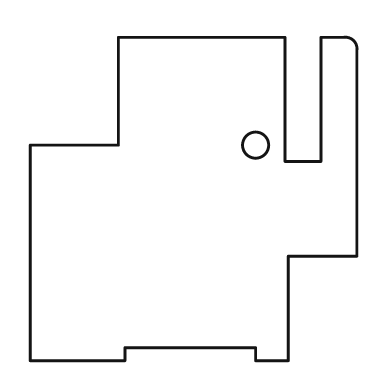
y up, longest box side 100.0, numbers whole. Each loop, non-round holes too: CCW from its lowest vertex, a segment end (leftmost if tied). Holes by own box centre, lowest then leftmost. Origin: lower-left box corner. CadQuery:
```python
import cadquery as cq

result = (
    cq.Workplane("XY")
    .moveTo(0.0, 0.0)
    .lineTo(29.0, 0.0)
    .lineTo(29.0, 4.0)
    .lineTo(69.0, 4.0)
    .lineTo(69.0, 0.0)
    .lineTo(79.0, 0.0)
    .lineTo(79.0, 32.0)
    .lineTo(100.0, 32.0)
    .lineTo(100.0, 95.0)
    .threePointArc((99.0, 98.0), (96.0, 99.0))
    .lineTo(89.0, 99.0)
    .lineTo(89.0, 61.0)
    .lineTo(78.0, 61.0)
    .lineTo(78.0, 99.0)
    .lineTo(27.0, 99.0)
    .lineTo(27.0, 66.0)
    .lineTo(0.0, 66.0)
    .close()
    .moveTo(69.0, 66.0)
    .circle(4.0)
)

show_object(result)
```